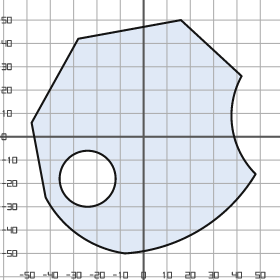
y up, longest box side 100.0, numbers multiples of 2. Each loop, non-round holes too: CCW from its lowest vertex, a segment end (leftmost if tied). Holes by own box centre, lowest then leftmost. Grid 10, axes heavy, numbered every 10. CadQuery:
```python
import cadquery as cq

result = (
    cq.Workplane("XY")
    .moveTo(-8.0, -50.0)
    .threePointArc((24.0, -40.0), (48.0, -16.0))
    .threePointArc((38.0, 4.0), (42.0, 26.0))
    .lineTo(16.0, 50.0)
    .lineTo(-28.0, 42.0)
    .lineTo(-48.0, 6.0)
    .lineTo(-42.0, -26.0)
    .threePointArc((-28.0, -42.0), (-8.0, -50.0))
    .close()
    .moveTo(-24.0, -18.0)
    .circle(12.0)
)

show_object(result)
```